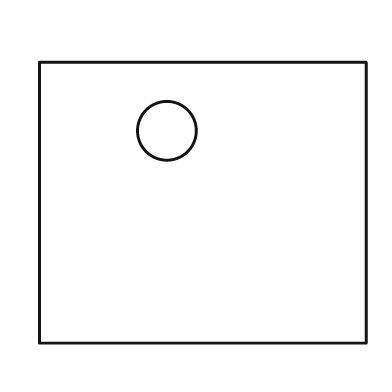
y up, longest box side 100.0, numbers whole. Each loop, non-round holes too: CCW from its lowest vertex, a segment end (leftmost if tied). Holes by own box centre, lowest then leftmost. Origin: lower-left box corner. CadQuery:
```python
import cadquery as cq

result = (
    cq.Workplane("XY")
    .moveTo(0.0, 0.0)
    .lineTo(100.0, 0.0)
    .lineTo(100.0, 86.0)
    .lineTo(0.0, 86.0)
    .close()
    .moveTo(39.0, 65.0)
    .circle(9.0)
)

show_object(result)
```